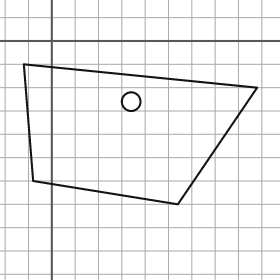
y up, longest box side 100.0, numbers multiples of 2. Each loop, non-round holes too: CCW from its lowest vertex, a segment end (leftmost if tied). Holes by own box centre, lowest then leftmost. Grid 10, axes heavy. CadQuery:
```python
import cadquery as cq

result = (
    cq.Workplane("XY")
    .moveTo(54.0, -70.0)
    .lineTo(88.0, -20.0)
    .lineTo(-12.0, -10.0)
    .lineTo(-8.0, -60.0)
    .close()
    .moveTo(34.0, -26.0)
    .circle(4.0)
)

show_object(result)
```